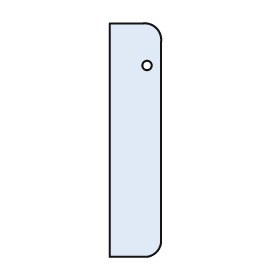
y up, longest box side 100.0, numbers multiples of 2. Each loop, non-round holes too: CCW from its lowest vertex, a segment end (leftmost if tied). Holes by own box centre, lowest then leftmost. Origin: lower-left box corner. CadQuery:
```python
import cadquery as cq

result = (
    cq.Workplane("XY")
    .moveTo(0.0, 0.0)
    .lineTo(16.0, 0.0)
    .threePointArc((20.0, 2.0), (22.0, 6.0))
    .lineTo(22.0, 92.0)
    .threePointArc((20.0, 98.0), (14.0, 100.0))
    .lineTo(0.0, 100.0)
    .close()
    .moveTo(16.0, 82.0)
    .circle(2.0)
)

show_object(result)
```